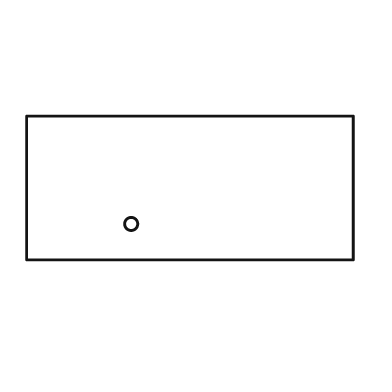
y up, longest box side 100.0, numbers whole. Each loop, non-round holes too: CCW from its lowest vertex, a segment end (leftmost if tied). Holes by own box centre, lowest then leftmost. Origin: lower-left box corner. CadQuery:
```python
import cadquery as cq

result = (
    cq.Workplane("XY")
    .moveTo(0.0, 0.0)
    .lineTo(100.0, 0.0)
    .lineTo(100.0, 44.0)
    .lineTo(0.0, 44.0)
    .close()
    .moveTo(32.0, 11.0)
    .circle(2.0)
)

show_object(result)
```